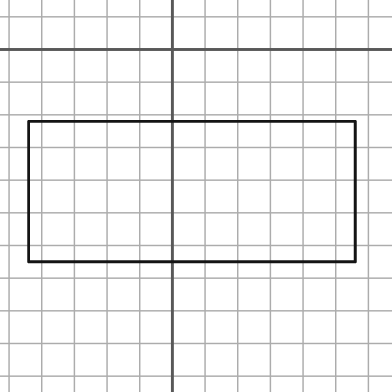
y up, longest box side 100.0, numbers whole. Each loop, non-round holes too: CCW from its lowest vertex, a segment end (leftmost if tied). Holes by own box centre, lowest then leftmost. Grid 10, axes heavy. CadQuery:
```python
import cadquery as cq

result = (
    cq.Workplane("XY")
    .moveTo(-44.0, -65.0)
    .lineTo(56.0, -65.0)
    .lineTo(56.0, -22.0)
    .lineTo(-44.0, -22.0)
    .close()
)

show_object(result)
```